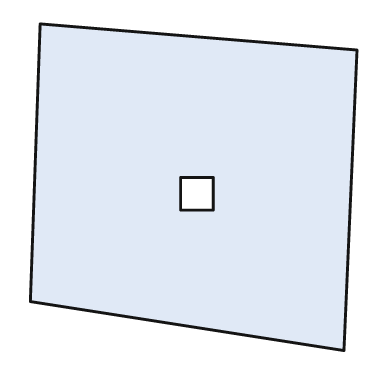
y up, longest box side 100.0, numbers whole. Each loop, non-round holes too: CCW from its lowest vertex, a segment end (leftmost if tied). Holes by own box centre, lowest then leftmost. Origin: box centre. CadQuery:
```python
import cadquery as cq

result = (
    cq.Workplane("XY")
    .moveTo(46.0, -50.0)
    .lineTo(50.0, 42.0)
    .lineTo(-47.0, 50.0)
    .lineTo(-50.0, -35.0)
    .close()
    .moveTo(-4.0, -7.0)
    .lineTo(6.0, -7.0)
    .lineTo(6.0, 3.0)
    .lineTo(-4.0, 3.0)
    .close()
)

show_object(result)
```